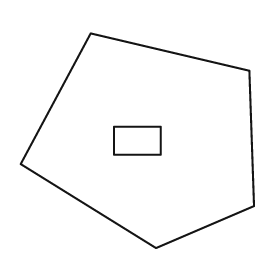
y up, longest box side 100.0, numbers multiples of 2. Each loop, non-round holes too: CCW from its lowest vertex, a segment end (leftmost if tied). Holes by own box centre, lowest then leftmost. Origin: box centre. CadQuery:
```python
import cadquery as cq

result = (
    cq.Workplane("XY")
    .moveTo(8.0, -46.0)
    .lineTo(50.0, -28.0)
    .lineTo(48.0, 30.0)
    .lineTo(-20.0, 46.0)
    .lineTo(-50.0, -10.0)
    .close()
    .moveTo(-10.0, -6.0)
    .lineTo(10.0, -6.0)
    .lineTo(10.0, 6.0)
    .lineTo(-10.0, 6.0)
    .close()
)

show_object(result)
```